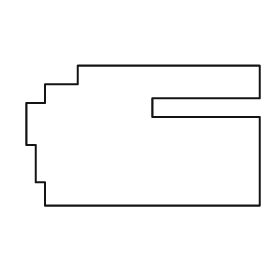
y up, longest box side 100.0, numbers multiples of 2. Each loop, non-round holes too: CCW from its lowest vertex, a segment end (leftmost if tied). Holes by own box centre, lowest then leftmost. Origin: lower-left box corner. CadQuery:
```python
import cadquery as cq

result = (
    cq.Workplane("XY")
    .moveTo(8.0, 0.0)
    .lineTo(100.0, 0.0)
    .lineTo(100.0, 38.0)
    .lineTo(54.0, 38.0)
    .lineTo(54.0, 46.0)
    .lineTo(100.0, 46.0)
    .lineTo(100.0, 60.0)
    .lineTo(22.0, 60.0)
    .lineTo(22.0, 52.0)
    .lineTo(8.0, 52.0)
    .lineTo(8.0, 44.0)
    .lineTo(0.0, 44.0)
    .lineTo(0.0, 26.0)
    .lineTo(4.0, 26.0)
    .lineTo(4.0, 10.0)
    .lineTo(8.0, 10.0)
    .close()
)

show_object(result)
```